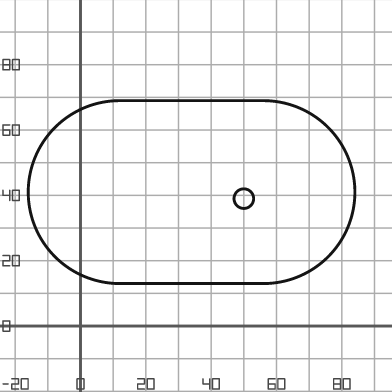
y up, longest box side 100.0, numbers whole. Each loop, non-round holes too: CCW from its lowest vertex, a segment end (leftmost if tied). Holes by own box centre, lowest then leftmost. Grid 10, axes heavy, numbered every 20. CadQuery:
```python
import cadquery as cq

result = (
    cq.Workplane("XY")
    .moveTo(12.0, 13.0)
    .lineTo(56.0, 13.0)
    .threePointArc((84.0, 41.0), (56.0, 69.0))
    .lineTo(12.0, 69.0)
    .threePointArc((-16.0, 41.0), (12.0, 13.0))
    .close()
    .moveTo(50.0, 39.0)
    .circle(3.0)
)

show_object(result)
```